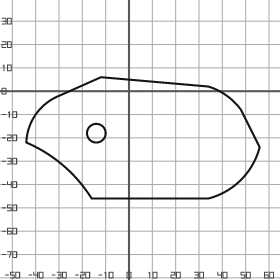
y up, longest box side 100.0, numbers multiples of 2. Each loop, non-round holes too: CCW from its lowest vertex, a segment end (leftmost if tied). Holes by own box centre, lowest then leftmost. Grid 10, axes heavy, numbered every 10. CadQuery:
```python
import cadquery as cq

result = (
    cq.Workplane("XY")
    .moveTo(-16.0, -46.0)
    .lineTo(34.0, -46.0)
    .threePointArc((48.0, -38.0), (56.0, -24.0))
    .lineTo(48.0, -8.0)
    .threePointArc((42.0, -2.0), (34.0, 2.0))
    .lineTo(-12.0, 6.0)
    .lineTo(-30.0, -2.0)
    .threePointArc((-40.0, -10.0), (-44.0, -22.0))
    .threePointArc((-28.0, -32.0), (-16.0, -46.0))
    .close()
    .moveTo(-14.0, -18.0)
    .circle(4.0)
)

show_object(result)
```